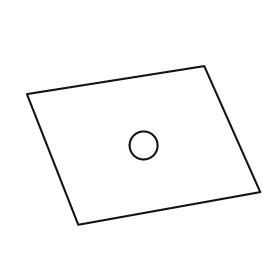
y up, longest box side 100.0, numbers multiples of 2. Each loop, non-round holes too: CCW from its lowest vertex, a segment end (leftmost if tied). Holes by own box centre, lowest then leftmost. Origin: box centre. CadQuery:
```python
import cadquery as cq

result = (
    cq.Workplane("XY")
    .moveTo(-28.0, -34.0)
    .lineTo(50.0, -20.0)
    .lineTo(26.0, 34.0)
    .lineTo(-50.0, 22.0)
    .close()
    .moveTo(0.0, 0.0)
    .circle(6.0)
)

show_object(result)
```